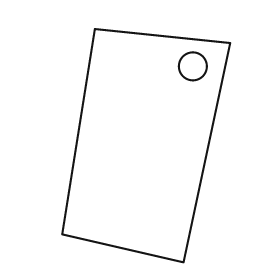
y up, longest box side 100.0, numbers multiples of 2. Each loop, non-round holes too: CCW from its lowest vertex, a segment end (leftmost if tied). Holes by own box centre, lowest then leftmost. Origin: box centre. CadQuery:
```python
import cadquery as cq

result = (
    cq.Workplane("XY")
    .moveTo(16.0, -50.0)
    .lineTo(36.0, 44.0)
    .lineTo(-22.0, 50.0)
    .lineTo(-36.0, -38.0)
    .close()
    .moveTo(20.0, 34.0)
    .circle(6.0)
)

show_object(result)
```